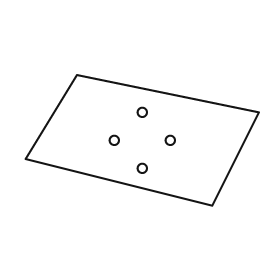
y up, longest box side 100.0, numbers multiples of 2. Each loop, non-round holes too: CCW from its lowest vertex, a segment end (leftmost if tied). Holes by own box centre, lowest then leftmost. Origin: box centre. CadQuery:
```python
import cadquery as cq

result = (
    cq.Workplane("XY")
    .moveTo(30.0, -28.0)
    .lineTo(50.0, 12.0)
    .lineTo(-28.0, 28.0)
    .lineTo(-50.0, -8.0)
    .close()
    .moveTo(0.0, -12.0)
    .circle(2.0)
    .moveTo(-12.0, 0.0)
    .circle(2.0)
    .moveTo(12.0, 0.0)
    .circle(2.0)
    .moveTo(0.0, 12.0)
    .circle(2.0)
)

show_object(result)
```